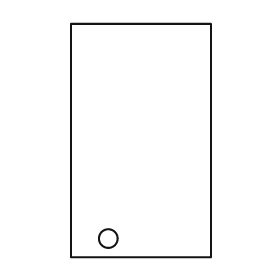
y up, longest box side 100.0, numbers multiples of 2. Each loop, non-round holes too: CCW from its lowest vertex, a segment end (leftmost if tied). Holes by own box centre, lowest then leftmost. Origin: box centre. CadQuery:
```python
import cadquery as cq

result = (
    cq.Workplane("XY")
    .moveTo(-30.0, -50.0)
    .lineTo(30.0, -50.0)
    .lineTo(30.0, 50.0)
    .lineTo(-30.0, 50.0)
    .close()
    .moveTo(-14.0, -42.0)
    .circle(4.0)
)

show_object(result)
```